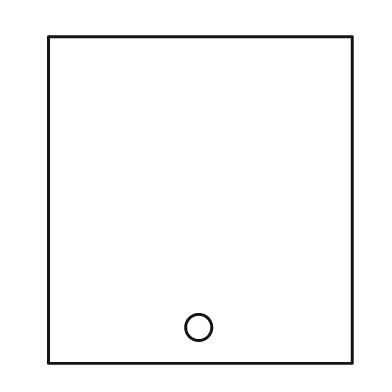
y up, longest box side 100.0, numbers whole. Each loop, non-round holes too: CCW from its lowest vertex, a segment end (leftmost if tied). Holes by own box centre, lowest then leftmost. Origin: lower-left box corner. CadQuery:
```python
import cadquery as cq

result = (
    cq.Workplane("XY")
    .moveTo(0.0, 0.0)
    .lineTo(93.0, 0.0)
    .lineTo(93.0, 100.0)
    .lineTo(0.0, 100.0)
    .close()
    .moveTo(46.0, 11.0)
    .circle(4.0)
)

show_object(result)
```